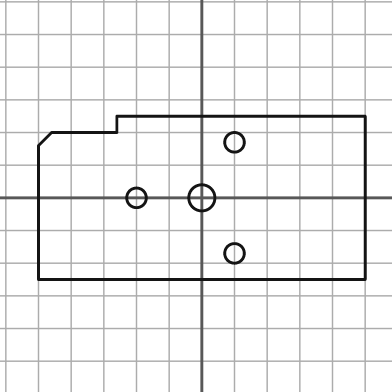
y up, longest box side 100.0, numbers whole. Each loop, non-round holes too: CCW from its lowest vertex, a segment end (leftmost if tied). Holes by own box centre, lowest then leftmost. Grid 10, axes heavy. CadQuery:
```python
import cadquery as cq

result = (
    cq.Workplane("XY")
    .moveTo(-50.0, -25.0)
    .lineTo(50.0, -25.0)
    .lineTo(50.0, 25.0)
    .lineTo(-26.0, 25.0)
    .lineTo(-26.0, 20.0)
    .lineTo(-46.0, 20.0)
    .lineTo(-50.0, 16.0)
    .close()
    .moveTo(10.0, -17.0)
    .circle(3.0)
    .moveTo(-20.0, 0.0)
    .circle(3.0)
    .moveTo(0.0, 0.0)
    .circle(4.0)
    .moveTo(10.0, 17.0)
    .circle(3.0)
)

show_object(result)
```